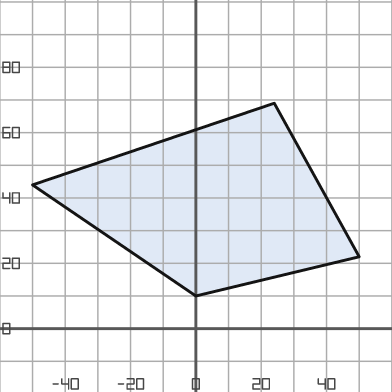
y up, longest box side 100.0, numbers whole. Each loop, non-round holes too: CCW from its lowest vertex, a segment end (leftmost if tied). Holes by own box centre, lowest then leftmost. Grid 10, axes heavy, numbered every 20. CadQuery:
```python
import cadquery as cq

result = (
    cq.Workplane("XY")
    .moveTo(0.0, 10.0)
    .lineTo(50.0, 22.0)
    .lineTo(24.0, 69.0)
    .lineTo(-50.0, 44.0)
    .close()
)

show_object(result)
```